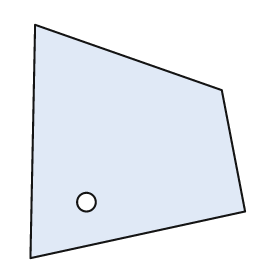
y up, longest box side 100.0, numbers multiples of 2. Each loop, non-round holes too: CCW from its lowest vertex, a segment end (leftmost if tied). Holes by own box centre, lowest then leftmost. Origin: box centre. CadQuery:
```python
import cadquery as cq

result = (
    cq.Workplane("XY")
    .moveTo(-46.0, -50.0)
    .lineTo(46.0, -30.0)
    .lineTo(36.0, 22.0)
    .lineTo(-44.0, 50.0)
    .close()
    .moveTo(-22.0, -26.0)
    .circle(4.0)
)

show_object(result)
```